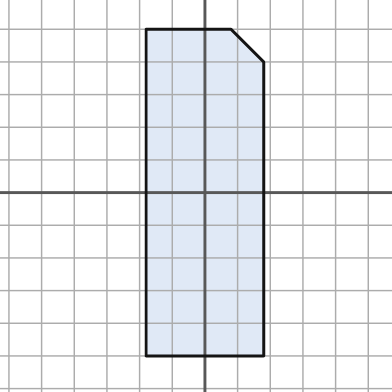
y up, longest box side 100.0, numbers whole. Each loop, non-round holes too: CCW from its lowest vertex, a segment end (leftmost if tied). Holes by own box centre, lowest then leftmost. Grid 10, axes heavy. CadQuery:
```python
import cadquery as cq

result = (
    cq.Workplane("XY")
    .moveTo(-18.0, -50.0)
    .lineTo(18.0, -50.0)
    .lineTo(18.0, 40.0)
    .lineTo(8.0, 50.0)
    .lineTo(-18.0, 50.0)
    .close()
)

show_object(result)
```